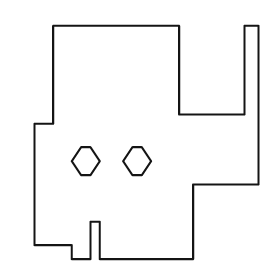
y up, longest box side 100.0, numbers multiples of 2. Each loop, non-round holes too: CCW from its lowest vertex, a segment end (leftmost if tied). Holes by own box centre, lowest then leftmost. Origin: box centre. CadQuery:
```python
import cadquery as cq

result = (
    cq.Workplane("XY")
    .moveTo(-32.0, -50.0)
    .lineTo(-24.0, -50.0)
    .lineTo(-24.0, -34.0)
    .lineTo(-20.0, -34.0)
    .lineTo(-20.0, -50.0)
    .lineTo(20.0, -50.0)
    .lineTo(20.0, -18.0)
    .lineTo(48.0, -18.0)
    .lineTo(48.0, 50.0)
    .lineTo(42.0, 50.0)
    .lineTo(42.0, 12.0)
    .lineTo(14.0, 12.0)
    .lineTo(14.0, 50.0)
    .lineTo(-40.0, 50.0)
    .lineTo(-40.0, 8.0)
    .lineTo(-48.0, 8.0)
    .lineTo(-48.0, -44.0)
    .lineTo(-32.0, -44.0)
    .close()
    .moveTo(-28.0, -14.0)
    .lineTo(-24.0, -14.0)
    .lineTo(-20.0, -8.0)
    .lineTo(-24.0, -2.0)
    .lineTo(-28.0, -2.0)
    .lineTo(-32.0, -8.0)
    .close()
    .moveTo(-6.0, -14.0)
    .lineTo(-2.0, -14.0)
    .lineTo(2.0, -8.0)
    .lineTo(-2.0, -2.0)
    .lineTo(-6.0, -2.0)
    .lineTo(-10.0, -8.0)
    .close()
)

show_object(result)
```